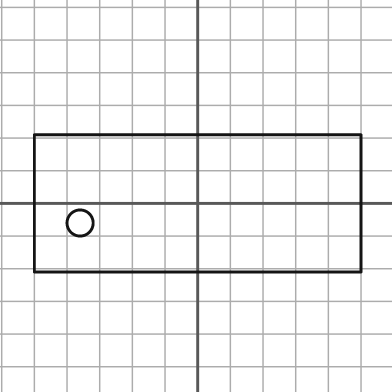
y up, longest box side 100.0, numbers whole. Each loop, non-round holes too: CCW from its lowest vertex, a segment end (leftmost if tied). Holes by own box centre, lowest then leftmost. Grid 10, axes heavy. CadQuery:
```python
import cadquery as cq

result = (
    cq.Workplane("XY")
    .moveTo(-50.0, -21.0)
    .lineTo(50.0, -21.0)
    .lineTo(50.0, 21.0)
    .lineTo(-50.0, 21.0)
    .close()
    .moveTo(-36.0, -6.0)
    .circle(4.0)
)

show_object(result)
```